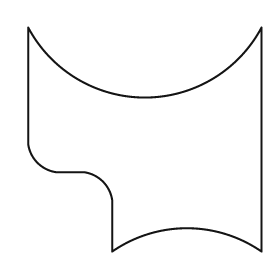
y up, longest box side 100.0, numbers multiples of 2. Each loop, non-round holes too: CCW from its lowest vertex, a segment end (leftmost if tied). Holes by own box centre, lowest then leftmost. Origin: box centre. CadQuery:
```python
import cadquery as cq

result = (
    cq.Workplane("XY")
    .moveTo(-14.0, -48.0)
    .threePointArc((18.0, -38.0), (50.0, -48.0))
    .lineTo(50.0, 48.0)
    .threePointArc((0.0, 18.0), (-50.0, 48.0))
    .lineTo(-50.0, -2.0)
    .threePointArc((-46.0, -10.0), (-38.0, -14.0))
    .lineTo(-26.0, -14.0)
    .threePointArc((-18.0, -18.0), (-14.0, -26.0))
    .close()
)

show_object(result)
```